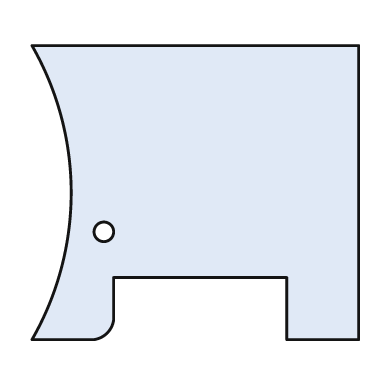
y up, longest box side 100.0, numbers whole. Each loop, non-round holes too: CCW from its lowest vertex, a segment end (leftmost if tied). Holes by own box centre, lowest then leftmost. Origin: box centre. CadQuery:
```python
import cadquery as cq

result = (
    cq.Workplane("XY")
    .moveTo(-50.0, -45.0)
    .lineTo(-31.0, -45.0)
    .threePointArc((-27.0, -43.0), (-25.0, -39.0))
    .lineTo(-25.0, -26.0)
    .lineTo(28.0, -26.0)
    .lineTo(28.0, -45.0)
    .lineTo(50.0, -45.0)
    .lineTo(50.0, 45.0)
    .lineTo(-50.0, 45.0)
    .threePointArc((-38.0, 0.0), (-50.0, -45.0))
    .close()
    .moveTo(-28.0, -12.0)
    .circle(3.0)
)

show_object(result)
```